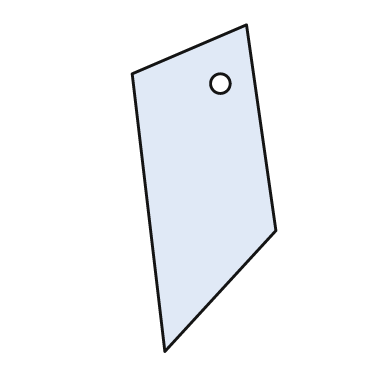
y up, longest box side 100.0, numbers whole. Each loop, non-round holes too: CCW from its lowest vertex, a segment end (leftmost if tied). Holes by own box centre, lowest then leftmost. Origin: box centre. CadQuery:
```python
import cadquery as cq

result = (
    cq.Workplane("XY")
    .moveTo(-12.0, -50.0)
    .lineTo(22.0, -13.0)
    .lineTo(13.0, 50.0)
    .lineTo(-22.0, 35.0)
    .close()
    .moveTo(5.0, 32.0)
    .circle(3.0)
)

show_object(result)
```